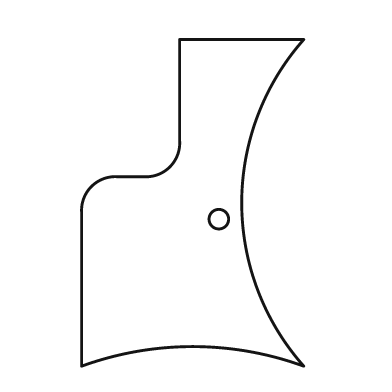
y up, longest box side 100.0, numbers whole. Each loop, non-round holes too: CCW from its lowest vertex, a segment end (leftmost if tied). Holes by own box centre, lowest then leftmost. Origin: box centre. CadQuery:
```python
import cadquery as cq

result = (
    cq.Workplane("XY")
    .moveTo(-34.0, -50.0)
    .threePointArc((0.0, -44.0), (34.0, -50.0))
    .threePointArc((15.0, 0.0), (34.0, 50.0))
    .lineTo(-4.0, 50.0)
    .lineTo(-4.0, 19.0)
    .threePointArc((-7.0, 11.0), (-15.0, 8.0))
    .lineTo(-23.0, 8.0)
    .threePointArc((-31.0, 5.0), (-34.0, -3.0))
    .close()
    .moveTo(8.0, -5.0)
    .circle(3.0)
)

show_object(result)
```